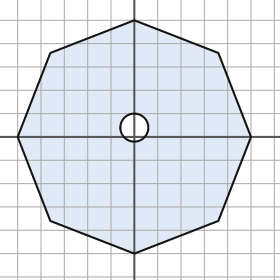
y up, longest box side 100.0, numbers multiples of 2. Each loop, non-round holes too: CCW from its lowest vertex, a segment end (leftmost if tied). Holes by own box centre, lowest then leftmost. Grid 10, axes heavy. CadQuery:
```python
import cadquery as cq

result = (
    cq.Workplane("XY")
    .moveTo(0.0, -50.0)
    .lineTo(36.0, -36.0)
    .lineTo(50.0, 0.0)
    .lineTo(36.0, 36.0)
    .lineTo(0.0, 50.0)
    .lineTo(-36.0, 36.0)
    .lineTo(-50.0, 0.0)
    .lineTo(-36.0, -36.0)
    .close()
    .moveTo(0.0, 4.0)
    .circle(6.0)
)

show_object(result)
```